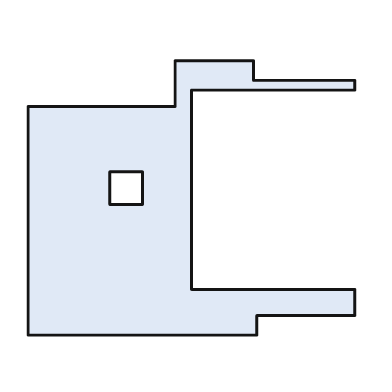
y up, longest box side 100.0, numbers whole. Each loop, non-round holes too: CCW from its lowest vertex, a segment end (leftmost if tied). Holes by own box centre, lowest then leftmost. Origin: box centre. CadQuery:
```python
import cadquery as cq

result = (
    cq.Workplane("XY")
    .moveTo(-50.0, -42.0)
    .lineTo(20.0, -42.0)
    .lineTo(20.0, -36.0)
    .lineTo(50.0, -36.0)
    .lineTo(50.0, -28.0)
    .lineTo(0.0, -28.0)
    .lineTo(0.0, 33.0)
    .lineTo(50.0, 33.0)
    .lineTo(50.0, 36.0)
    .lineTo(19.0, 36.0)
    .lineTo(19.0, 42.0)
    .lineTo(-5.0, 42.0)
    .lineTo(-5.0, 28.0)
    .lineTo(-50.0, 28.0)
    .close()
    .moveTo(-25.0, -2.0)
    .lineTo(-15.0, -2.0)
    .lineTo(-15.0, 8.0)
    .lineTo(-25.0, 8.0)
    .close()
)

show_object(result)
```